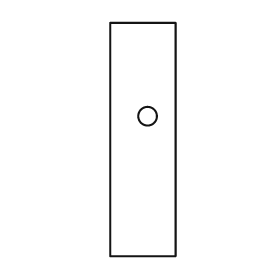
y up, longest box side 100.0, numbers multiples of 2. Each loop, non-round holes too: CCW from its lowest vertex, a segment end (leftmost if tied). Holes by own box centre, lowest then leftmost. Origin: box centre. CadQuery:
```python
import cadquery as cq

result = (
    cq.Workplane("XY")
    .moveTo(-14.0, -50.0)
    .lineTo(14.0, -50.0)
    .lineTo(14.0, 50.0)
    .lineTo(-14.0, 50.0)
    .close()
    .moveTo(2.0, 10.0)
    .circle(4.0)
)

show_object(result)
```